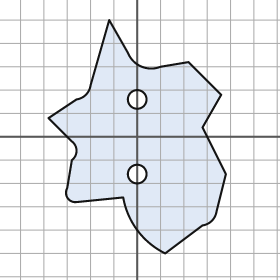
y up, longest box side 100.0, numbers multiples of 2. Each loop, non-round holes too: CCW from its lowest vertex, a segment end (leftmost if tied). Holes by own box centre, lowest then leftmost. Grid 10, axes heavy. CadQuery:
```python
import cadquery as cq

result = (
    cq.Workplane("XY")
    .moveTo(12.0, -50.0)
    .lineTo(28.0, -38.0)
    .threePointArc((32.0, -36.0), (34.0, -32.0))
    .lineTo(38.0, -16.0)
    .lineTo(28.0, 4.0)
    .lineTo(36.0, 18.0)
    .lineTo(22.0, 32.0)
    .lineTo(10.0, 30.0)
    .threePointArc((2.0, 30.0), (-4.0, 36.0))
    .lineTo(-12.0, 50.0)
    .lineTo(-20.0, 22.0)
    .threePointArc((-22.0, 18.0), (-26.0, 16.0))
    .lineTo(-38.0, 8.0)
    .lineTo(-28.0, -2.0)
    .threePointArc((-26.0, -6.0), (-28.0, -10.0))
    .lineTo(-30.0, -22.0)
    .threePointArc((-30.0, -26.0), (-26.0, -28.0))
    .lineTo(-6.0, -26.0)
    .threePointArc((0.0, -40.0), (12.0, -50.0))
    .close()
    .moveTo(0.0, -16.0)
    .circle(4.0)
    .moveTo(0.0, 16.0)
    .circle(4.0)
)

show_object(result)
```